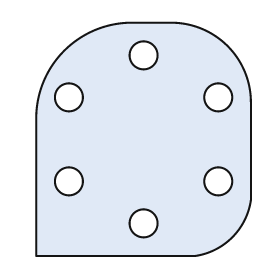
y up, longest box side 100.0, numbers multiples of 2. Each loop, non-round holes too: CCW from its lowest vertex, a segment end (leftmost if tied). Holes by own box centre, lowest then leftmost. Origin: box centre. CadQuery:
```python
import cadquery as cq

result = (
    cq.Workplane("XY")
    .moveTo(-46.0, -50.0)
    .lineTo(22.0, -50.0)
    .threePointArc((38.0, -42.0), (46.0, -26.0))
    .lineTo(46.0, 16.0)
    .threePointArc((36.0, 40.0), (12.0, 50.0))
    .lineTo(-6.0, 50.0)
    .threePointArc((-34.0, 38.0), (-46.0, 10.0))
    .close()
    .moveTo(0.0, -36.0)
    .circle(6.0)
    .moveTo(-32.0, -18.0)
    .circle(6.0)
    .moveTo(32.0, -18.0)
    .circle(6.0)
    .moveTo(-32.0, 18.0)
    .circle(6.0)
    .moveTo(32.0, 18.0)
    .circle(6.0)
    .moveTo(0.0, 36.0)
    .circle(6.0)
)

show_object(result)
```